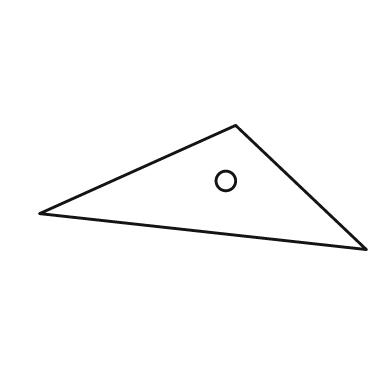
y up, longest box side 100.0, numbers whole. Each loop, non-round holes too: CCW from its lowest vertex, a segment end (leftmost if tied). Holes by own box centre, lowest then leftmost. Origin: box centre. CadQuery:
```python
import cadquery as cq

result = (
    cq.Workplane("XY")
    .moveTo(50.0, -19.0)
    .lineTo(10.0, 19.0)
    .lineTo(-50.0, -8.0)
    .close()
    .moveTo(7.0, 2.0)
    .circle(3.0)
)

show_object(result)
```